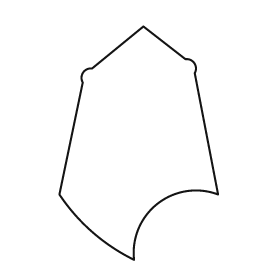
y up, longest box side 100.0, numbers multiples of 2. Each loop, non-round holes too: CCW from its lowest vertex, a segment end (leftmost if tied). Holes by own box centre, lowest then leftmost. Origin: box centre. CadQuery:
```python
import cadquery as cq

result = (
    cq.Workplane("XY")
    .moveTo(-2.0, -50.0)
    .threePointArc((8.0, -26.0), (34.0, -22.0))
    .lineTo(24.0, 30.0)
    .threePointArc((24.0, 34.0), (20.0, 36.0))
    .lineTo(2.0, 50.0)
    .lineTo(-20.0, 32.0)
    .threePointArc((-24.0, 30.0), (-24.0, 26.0))
    .lineTo(-34.0, -22.0)
    .threePointArc((-20.0, -38.0), (-2.0, -50.0))
    .close()
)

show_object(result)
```